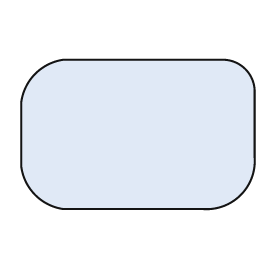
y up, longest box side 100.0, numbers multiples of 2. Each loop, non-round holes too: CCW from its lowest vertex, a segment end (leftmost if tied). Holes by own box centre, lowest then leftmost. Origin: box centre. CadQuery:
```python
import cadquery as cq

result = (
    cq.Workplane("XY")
    .moveTo(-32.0, -32.0)
    .lineTo(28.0, -32.0)
    .threePointArc((44.0, -26.0), (50.0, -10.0))
    .lineTo(50.0, 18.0)
    .threePointArc((46.0, 28.0), (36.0, 32.0))
    .lineTo(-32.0, 32.0)
    .threePointArc((-44.0, 26.0), (-50.0, 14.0))
    .lineTo(-50.0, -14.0)
    .threePointArc((-44.0, -26.0), (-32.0, -32.0))
    .close()
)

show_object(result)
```